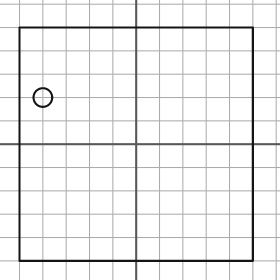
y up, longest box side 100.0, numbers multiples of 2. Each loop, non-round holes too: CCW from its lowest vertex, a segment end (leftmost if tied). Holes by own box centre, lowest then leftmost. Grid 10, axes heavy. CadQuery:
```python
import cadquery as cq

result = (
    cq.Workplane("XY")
    .moveTo(-50.0, -50.0)
    .lineTo(50.0, -50.0)
    .lineTo(50.0, 50.0)
    .lineTo(-50.0, 50.0)
    .close()
    .moveTo(-40.0, 20.0)
    .circle(4.0)
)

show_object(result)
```